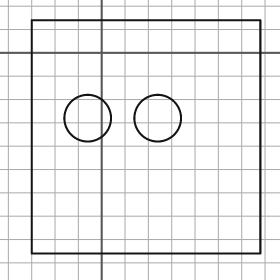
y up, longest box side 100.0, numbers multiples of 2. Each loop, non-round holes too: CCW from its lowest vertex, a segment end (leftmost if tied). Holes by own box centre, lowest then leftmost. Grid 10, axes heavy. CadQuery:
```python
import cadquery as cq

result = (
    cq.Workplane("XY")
    .moveTo(-30.0, -86.0)
    .lineTo(68.0, -86.0)
    .lineTo(68.0, 14.0)
    .lineTo(-30.0, 14.0)
    .close()
    .moveTo(-6.0, -28.0)
    .circle(10.0)
    .moveTo(24.0, -28.0)
    .circle(10.0)
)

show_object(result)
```